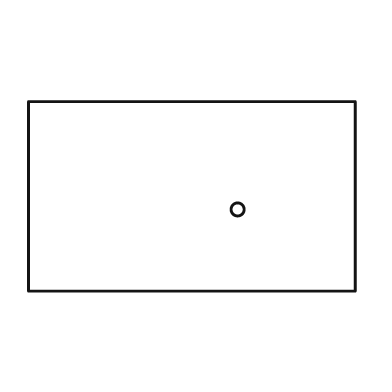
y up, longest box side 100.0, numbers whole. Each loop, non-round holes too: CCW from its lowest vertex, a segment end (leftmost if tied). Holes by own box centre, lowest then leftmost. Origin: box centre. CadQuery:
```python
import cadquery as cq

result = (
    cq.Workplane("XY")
    .moveTo(-50.0, -29.0)
    .lineTo(50.0, -29.0)
    .lineTo(50.0, 29.0)
    .lineTo(-50.0, 29.0)
    .close()
    .moveTo(14.0, -4.0)
    .circle(2.0)
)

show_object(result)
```